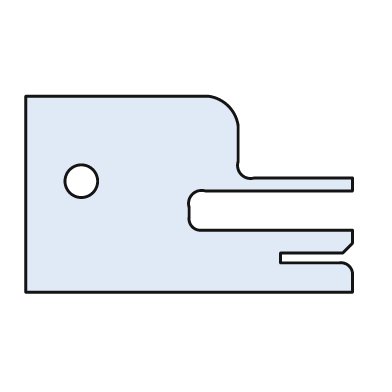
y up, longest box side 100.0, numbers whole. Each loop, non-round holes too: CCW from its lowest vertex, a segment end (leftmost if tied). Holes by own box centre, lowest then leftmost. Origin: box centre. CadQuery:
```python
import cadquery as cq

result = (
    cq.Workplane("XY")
    .moveTo(-50.0, -30.0)
    .lineTo(50.0, -30.0)
    .lineTo(50.0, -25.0)
    .threePointArc((49.0, -22.0), (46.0, -21.0))
    .lineTo(28.0, -21.0)
    .lineTo(28.0, -18.0)
    .lineTo(47.0, -18.0)
    .lineTo(50.0, -15.0)
    .lineTo(50.0, -11.0)
    .lineTo(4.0, -11.0)
    .threePointArc((1.0, -10.0), (0.0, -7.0))
    .lineTo(0.0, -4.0)
    .threePointArc((1.0, 0.0), (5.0, 1.0))
    .lineTo(50.0, 1.0)
    .lineTo(50.0, 5.0)
    .lineTo(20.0, 5.0)
    .threePointArc((16.0, 6.0), (15.0, 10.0))
    .lineTo(15.0, 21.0)
    .threePointArc((12.0, 27.0), (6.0, 30.0))
    .lineTo(-50.0, 30.0)
    .close()
    .moveTo(-33.0, 4.0)
    .circle(5.0)
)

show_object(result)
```